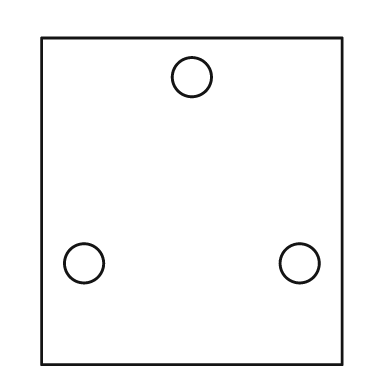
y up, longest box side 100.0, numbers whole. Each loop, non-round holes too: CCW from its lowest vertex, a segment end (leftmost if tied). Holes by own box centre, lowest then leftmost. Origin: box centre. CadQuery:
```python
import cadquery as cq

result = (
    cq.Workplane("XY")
    .moveTo(-46.0, -50.0)
    .lineTo(46.0, -50.0)
    .lineTo(46.0, 50.0)
    .lineTo(-46.0, 50.0)
    .close()
    .moveTo(-33.0, -19.0)
    .circle(6.0)
    .moveTo(33.0, -19.0)
    .circle(6.0)
    .moveTo(0.0, 38.0)
    .circle(6.0)
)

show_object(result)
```